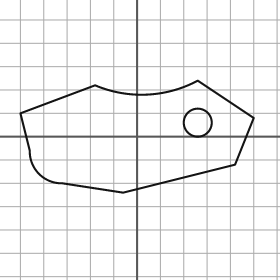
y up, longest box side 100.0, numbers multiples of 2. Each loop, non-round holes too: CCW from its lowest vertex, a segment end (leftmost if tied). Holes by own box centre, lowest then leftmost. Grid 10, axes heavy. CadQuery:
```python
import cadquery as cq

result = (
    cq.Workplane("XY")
    .moveTo(-6.0, -24.0)
    .lineTo(42.0, -12.0)
    .lineTo(50.0, 8.0)
    .lineTo(26.0, 24.0)
    .threePointArc((4.0, 18.0), (-18.0, 22.0))
    .lineTo(-50.0, 10.0)
    .lineTo(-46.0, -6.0)
    .threePointArc((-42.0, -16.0), (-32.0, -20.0))
    .close()
    .moveTo(26.0, 6.0)
    .circle(6.0)
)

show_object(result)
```